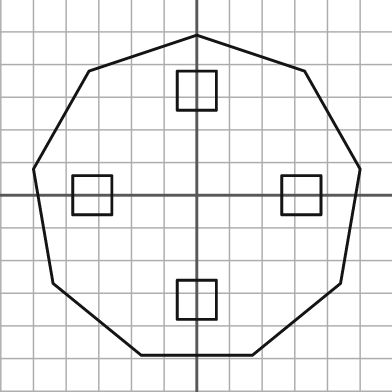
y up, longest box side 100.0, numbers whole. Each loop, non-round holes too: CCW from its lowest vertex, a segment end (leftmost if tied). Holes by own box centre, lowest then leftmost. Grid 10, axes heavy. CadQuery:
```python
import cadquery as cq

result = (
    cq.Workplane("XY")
    .moveTo(-17.0, -49.0)
    .lineTo(17.0, -49.0)
    .lineTo(44.0, -27.0)
    .lineTo(50.0, 8.0)
    .lineTo(33.0, 38.0)
    .lineTo(0.0, 49.0)
    .lineTo(-33.0, 38.0)
    .lineTo(-50.0, 8.0)
    .lineTo(-44.0, -27.0)
    .close()
    .moveTo(-6.0, -38.0)
    .lineTo(6.0, -38.0)
    .lineTo(6.0, -26.0)
    .lineTo(-6.0, -26.0)
    .close()
    .moveTo(-38.0, -6.0)
    .lineTo(-26.0, -6.0)
    .lineTo(-26.0, 6.0)
    .lineTo(-38.0, 6.0)
    .close()
    .moveTo(26.0, -6.0)
    .lineTo(38.0, -6.0)
    .lineTo(38.0, 6.0)
    .lineTo(26.0, 6.0)
    .close()
    .moveTo(-6.0, 26.0)
    .lineTo(6.0, 26.0)
    .lineTo(6.0, 38.0)
    .lineTo(-6.0, 38.0)
    .close()
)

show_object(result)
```